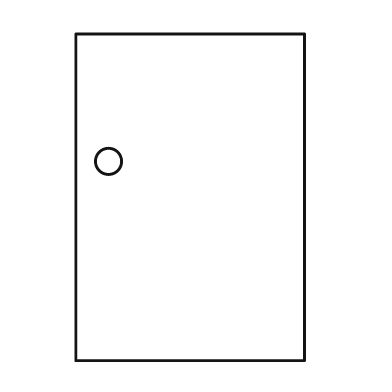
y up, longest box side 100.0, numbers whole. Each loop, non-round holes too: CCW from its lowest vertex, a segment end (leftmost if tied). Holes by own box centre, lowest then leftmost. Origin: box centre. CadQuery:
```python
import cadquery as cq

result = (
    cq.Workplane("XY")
    .moveTo(-35.0, -50.0)
    .lineTo(35.0, -50.0)
    .lineTo(35.0, 50.0)
    .lineTo(-35.0, 50.0)
    .close()
    .moveTo(-25.0, 11.0)
    .circle(4.0)
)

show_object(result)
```